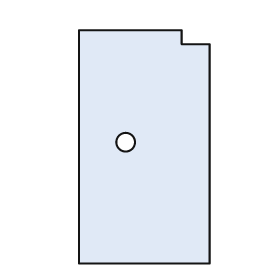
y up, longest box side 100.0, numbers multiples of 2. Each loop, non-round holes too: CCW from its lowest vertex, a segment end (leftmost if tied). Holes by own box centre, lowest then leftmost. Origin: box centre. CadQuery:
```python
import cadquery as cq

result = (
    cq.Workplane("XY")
    .moveTo(-28.0, -50.0)
    .lineTo(28.0, -50.0)
    .lineTo(28.0, 44.0)
    .lineTo(16.0, 44.0)
    .lineTo(16.0, 50.0)
    .lineTo(-28.0, 50.0)
    .close()
    .moveTo(-8.0, 2.0)
    .circle(4.0)
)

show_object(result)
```